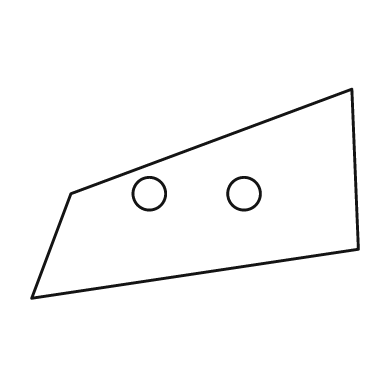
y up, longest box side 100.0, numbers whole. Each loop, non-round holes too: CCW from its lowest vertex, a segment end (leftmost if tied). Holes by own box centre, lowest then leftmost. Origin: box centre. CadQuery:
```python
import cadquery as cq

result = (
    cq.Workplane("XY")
    .moveTo(-50.0, -32.0)
    .lineTo(50.0, -17.0)
    .lineTo(48.0, 32.0)
    .lineTo(-38.0, 0.0)
    .close()
    .moveTo(-14.0, 0.0)
    .circle(5.0)
    .moveTo(15.0, 0.0)
    .circle(5.0)
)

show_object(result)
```